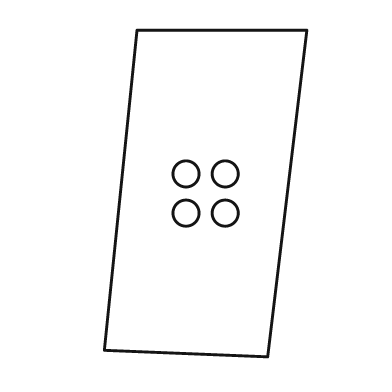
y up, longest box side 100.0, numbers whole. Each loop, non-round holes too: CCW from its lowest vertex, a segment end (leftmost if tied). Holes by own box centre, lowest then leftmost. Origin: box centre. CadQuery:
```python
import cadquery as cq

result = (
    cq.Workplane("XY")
    .moveTo(19.0, -50.0)
    .lineTo(31.0, 50.0)
    .lineTo(-21.0, 50.0)
    .lineTo(-31.0, -48.0)
    .close()
    .moveTo(-6.0, -6.0)
    .circle(4.0)
    .moveTo(6.0, -6.0)
    .circle(4.0)
    .moveTo(-6.0, 6.0)
    .circle(4.0)
    .moveTo(6.0, 6.0)
    .circle(4.0)
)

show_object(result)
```